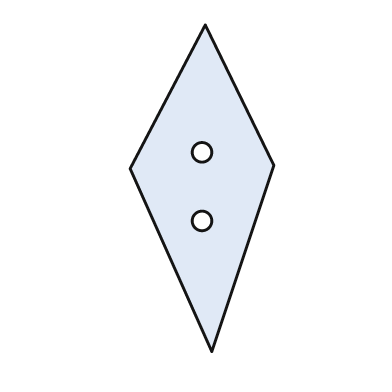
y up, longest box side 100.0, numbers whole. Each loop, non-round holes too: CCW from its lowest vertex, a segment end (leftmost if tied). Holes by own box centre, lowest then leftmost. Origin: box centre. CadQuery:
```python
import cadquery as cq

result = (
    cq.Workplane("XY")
    .moveTo(3.0, -50.0)
    .lineTo(22.0, 7.0)
    .lineTo(1.0, 50.0)
    .lineTo(-22.0, 6.0)
    .close()
    .moveTo(0.0, -10.0)
    .circle(3.0)
    .moveTo(0.0, 11.0)
    .circle(3.0)
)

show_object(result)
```